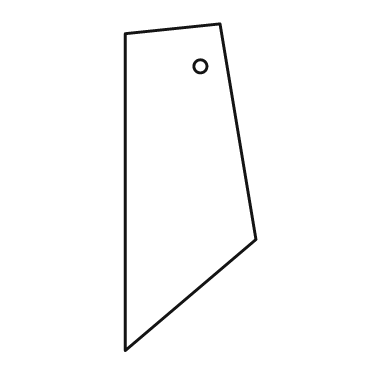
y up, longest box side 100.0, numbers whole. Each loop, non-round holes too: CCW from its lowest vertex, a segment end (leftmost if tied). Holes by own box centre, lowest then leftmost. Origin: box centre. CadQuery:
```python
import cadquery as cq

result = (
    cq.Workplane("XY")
    .moveTo(-20.0, -50.0)
    .lineTo(20.0, -16.0)
    .lineTo(9.0, 50.0)
    .lineTo(-20.0, 47.0)
    .close()
    .moveTo(3.0, 37.0)
    .circle(2.0)
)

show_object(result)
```